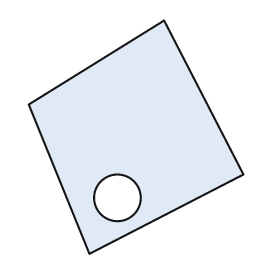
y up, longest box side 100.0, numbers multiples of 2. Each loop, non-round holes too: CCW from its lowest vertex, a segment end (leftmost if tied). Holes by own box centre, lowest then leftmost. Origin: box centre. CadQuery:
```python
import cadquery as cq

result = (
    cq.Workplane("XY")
    .moveTo(-20.0, -50.0)
    .lineTo(46.0, -16.0)
    .lineTo(12.0, 50.0)
    .lineTo(-46.0, 14.0)
    .close()
    .moveTo(-8.0, -26.0)
    .circle(10.0)
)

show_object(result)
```